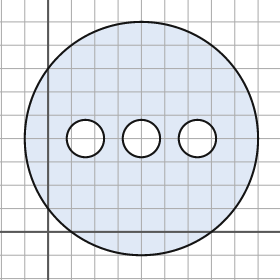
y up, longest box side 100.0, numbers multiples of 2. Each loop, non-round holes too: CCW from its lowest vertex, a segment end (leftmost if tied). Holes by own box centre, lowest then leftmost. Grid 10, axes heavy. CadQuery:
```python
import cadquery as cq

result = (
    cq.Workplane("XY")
    .moveTo(40.0, 40.0)
    .circle(50.0)
    .moveTo(16.0, 40.0)
    .circle(8.0)
    .moveTo(40.0, 40.0)
    .circle(8.0)
    .moveTo(64.0, 40.0)
    .circle(8.0)
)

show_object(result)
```